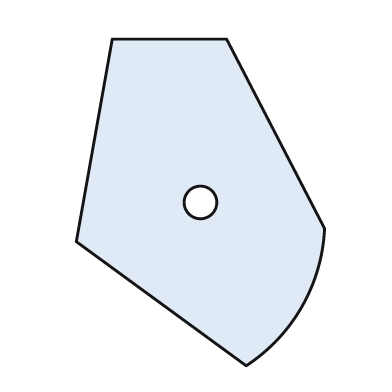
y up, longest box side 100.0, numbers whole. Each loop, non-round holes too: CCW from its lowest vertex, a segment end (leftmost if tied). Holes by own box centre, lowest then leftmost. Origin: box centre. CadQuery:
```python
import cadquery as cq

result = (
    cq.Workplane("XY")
    .moveTo(14.0, -50.0)
    .threePointArc((31.0, -32.0), (38.0, -8.0))
    .lineTo(8.0, 50.0)
    .lineTo(-27.0, 50.0)
    .lineTo(-38.0, -12.0)
    .close()
    .moveTo(0.0, 0.0)
    .circle(5.0)
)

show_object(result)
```